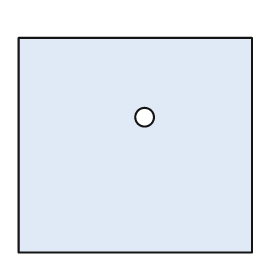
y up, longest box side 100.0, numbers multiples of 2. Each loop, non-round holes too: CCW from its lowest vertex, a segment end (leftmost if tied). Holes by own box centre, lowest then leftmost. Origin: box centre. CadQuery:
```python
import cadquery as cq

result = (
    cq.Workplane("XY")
    .moveTo(-50.0, -46.0)
    .lineTo(50.0, -46.0)
    .lineTo(50.0, 46.0)
    .lineTo(-50.0, 46.0)
    .close()
    .moveTo(4.0, 12.0)
    .circle(4.0)
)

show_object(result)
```